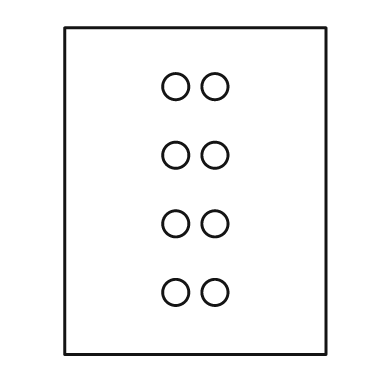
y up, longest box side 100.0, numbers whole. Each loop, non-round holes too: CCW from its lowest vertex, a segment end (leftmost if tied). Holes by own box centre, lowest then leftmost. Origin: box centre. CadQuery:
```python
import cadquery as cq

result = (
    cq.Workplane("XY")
    .moveTo(-40.0, -50.0)
    .lineTo(40.0, -50.0)
    .lineTo(40.0, 50.0)
    .lineTo(-40.0, 50.0)
    .close()
    .moveTo(-6.0, -31.0)
    .circle(4.0)
    .moveTo(6.0, -31.0)
    .circle(4.0)
    .moveTo(-6.0, -10.0)
    .circle(4.0)
    .moveTo(6.0, -10.0)
    .circle(4.0)
    .moveTo(-6.0, 11.0)
    .circle(4.0)
    .moveTo(6.0, 11.0)
    .circle(4.0)
    .moveTo(-6.0, 32.0)
    .circle(4.0)
    .moveTo(6.0, 32.0)
    .circle(4.0)
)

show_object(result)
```